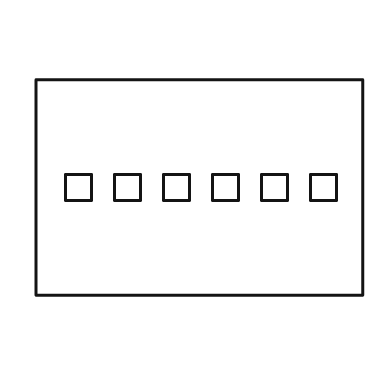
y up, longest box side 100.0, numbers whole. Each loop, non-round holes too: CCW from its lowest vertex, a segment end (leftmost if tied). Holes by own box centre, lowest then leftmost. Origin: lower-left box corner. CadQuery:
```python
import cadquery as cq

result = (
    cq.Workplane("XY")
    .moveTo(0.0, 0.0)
    .lineTo(100.0, 0.0)
    .lineTo(100.0, 66.0)
    .lineTo(0.0, 66.0)
    .close()
    .moveTo(9.0, 29.0)
    .lineTo(17.0, 29.0)
    .lineTo(17.0, 37.0)
    .lineTo(9.0, 37.0)
    .close()
    .moveTo(24.0, 29.0)
    .lineTo(32.0, 29.0)
    .lineTo(32.0, 37.0)
    .lineTo(24.0, 37.0)
    .close()
    .moveTo(39.0, 29.0)
    .lineTo(47.0, 29.0)
    .lineTo(47.0, 37.0)
    .lineTo(39.0, 37.0)
    .close()
    .moveTo(54.0, 29.0)
    .lineTo(62.0, 29.0)
    .lineTo(62.0, 37.0)
    .lineTo(54.0, 37.0)
    .close()
    .moveTo(69.0, 29.0)
    .lineTo(77.0, 29.0)
    .lineTo(77.0, 37.0)
    .lineTo(69.0, 37.0)
    .close()
    .moveTo(84.0, 29.0)
    .lineTo(92.0, 29.0)
    .lineTo(92.0, 37.0)
    .lineTo(84.0, 37.0)
    .close()
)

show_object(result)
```